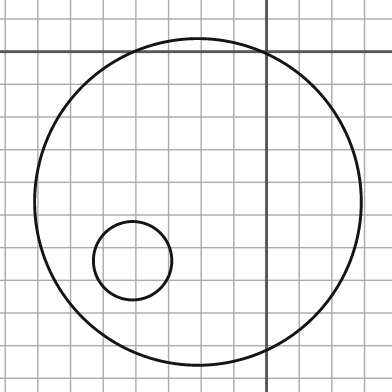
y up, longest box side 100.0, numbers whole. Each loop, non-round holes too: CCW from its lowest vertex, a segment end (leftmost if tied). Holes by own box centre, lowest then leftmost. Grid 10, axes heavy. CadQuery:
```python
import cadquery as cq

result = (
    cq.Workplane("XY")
    .moveTo(-21.0, -46.0)
    .circle(50.0)
    .moveTo(-41.0, -64.0)
    .circle(12.0)
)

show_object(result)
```